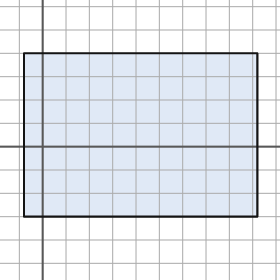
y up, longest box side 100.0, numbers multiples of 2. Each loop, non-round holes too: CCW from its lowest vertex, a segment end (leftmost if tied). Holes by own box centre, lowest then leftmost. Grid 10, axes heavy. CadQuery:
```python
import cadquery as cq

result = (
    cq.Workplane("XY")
    .moveTo(-8.0, -30.0)
    .lineTo(92.0, -30.0)
    .lineTo(92.0, 40.0)
    .lineTo(-8.0, 40.0)
    .close()
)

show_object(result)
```